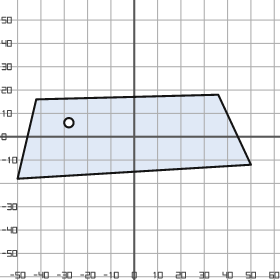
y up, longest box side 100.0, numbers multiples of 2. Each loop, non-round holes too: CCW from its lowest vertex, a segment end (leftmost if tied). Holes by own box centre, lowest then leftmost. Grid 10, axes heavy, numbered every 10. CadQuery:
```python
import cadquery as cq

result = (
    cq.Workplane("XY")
    .moveTo(-50.0, -18.0)
    .lineTo(50.0, -12.0)
    .lineTo(36.0, 18.0)
    .lineTo(-42.0, 16.0)
    .close()
    .moveTo(-28.0, 6.0)
    .circle(2.0)
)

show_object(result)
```